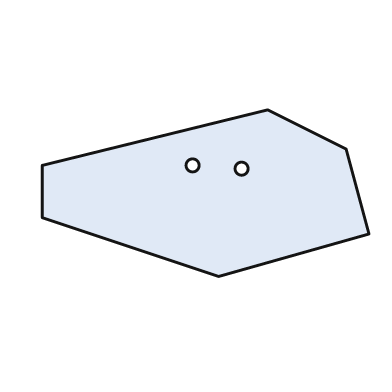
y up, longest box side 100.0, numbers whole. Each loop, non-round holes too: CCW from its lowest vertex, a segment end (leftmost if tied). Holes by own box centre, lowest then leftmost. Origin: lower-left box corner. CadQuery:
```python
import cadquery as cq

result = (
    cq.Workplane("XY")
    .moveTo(54.0, 0.0)
    .lineTo(100.0, 13.0)
    .lineTo(93.0, 39.0)
    .lineTo(69.0, 51.0)
    .lineTo(0.0, 34.0)
    .lineTo(0.0, 18.0)
    .close()
    .moveTo(61.0, 33.0)
    .circle(2.0)
    .moveTo(46.0, 34.0)
    .circle(2.0)
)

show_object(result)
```